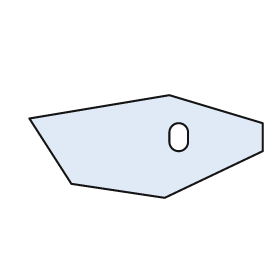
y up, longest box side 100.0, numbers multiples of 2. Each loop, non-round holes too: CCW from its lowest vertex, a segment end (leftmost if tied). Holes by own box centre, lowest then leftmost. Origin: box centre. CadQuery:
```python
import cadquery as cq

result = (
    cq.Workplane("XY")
    .moveTo(8.0, -22.0)
    .lineTo(50.0, -2.0)
    .lineTo(50.0, 10.0)
    .lineTo(10.0, 22.0)
    .lineTo(-50.0, 12.0)
    .lineTo(-32.0, -16.0)
    .close()
    .moveTo(10.0, 2.0)
    .threePointArc((14.0, -2.0), (18.0, 2.0))
    .lineTo(18.0, 6.0)
    .threePointArc((14.0, 10.0), (10.0, 6.0))
    .close()
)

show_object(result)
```